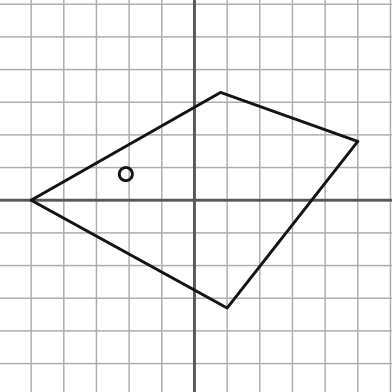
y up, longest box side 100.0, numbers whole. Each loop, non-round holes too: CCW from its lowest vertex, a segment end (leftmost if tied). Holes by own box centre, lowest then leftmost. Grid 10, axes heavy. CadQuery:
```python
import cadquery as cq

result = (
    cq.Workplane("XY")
    .moveTo(10.0, -33.0)
    .lineTo(50.0, 18.0)
    .lineTo(8.0, 33.0)
    .lineTo(-50.0, 0.0)
    .close()
    .moveTo(-21.0, 8.0)
    .circle(2.0)
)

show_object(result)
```